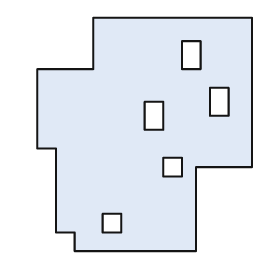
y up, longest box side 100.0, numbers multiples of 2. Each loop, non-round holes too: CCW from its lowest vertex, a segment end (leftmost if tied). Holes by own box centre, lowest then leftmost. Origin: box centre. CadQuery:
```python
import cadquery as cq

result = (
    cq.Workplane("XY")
    .moveTo(-30.0, -50.0)
    .lineTo(22.0, -50.0)
    .lineTo(22.0, -14.0)
    .lineTo(46.0, -14.0)
    .lineTo(46.0, 50.0)
    .lineTo(-22.0, 50.0)
    .lineTo(-22.0, 28.0)
    .lineTo(-46.0, 28.0)
    .lineTo(-46.0, -6.0)
    .lineTo(-38.0, -6.0)
    .lineTo(-38.0, -42.0)
    .lineTo(-30.0, -42.0)
    .close()
    .moveTo(-18.0, -42.0)
    .lineTo(-10.0, -42.0)
    .lineTo(-10.0, -34.0)
    .lineTo(-18.0, -34.0)
    .close()
    .moveTo(8.0, -18.0)
    .lineTo(16.0, -18.0)
    .lineTo(16.0, -10.0)
    .lineTo(8.0, -10.0)
    .close()
    .moveTo(0.0, 2.0)
    .lineTo(8.0, 2.0)
    .lineTo(8.0, 14.0)
    .lineTo(0.0, 14.0)
    .close()
    .moveTo(28.0, 8.0)
    .lineTo(36.0, 8.0)
    .lineTo(36.0, 20.0)
    .lineTo(28.0, 20.0)
    .close()
    .moveTo(16.0, 28.0)
    .lineTo(24.0, 28.0)
    .lineTo(24.0, 40.0)
    .lineTo(16.0, 40.0)
    .close()
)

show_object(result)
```